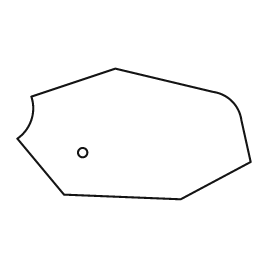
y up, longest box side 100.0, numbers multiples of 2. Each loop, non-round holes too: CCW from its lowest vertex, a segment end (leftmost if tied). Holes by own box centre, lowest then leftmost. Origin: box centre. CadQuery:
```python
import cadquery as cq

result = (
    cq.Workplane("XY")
    .moveTo(20.0, -28.0)
    .lineTo(50.0, -12.0)
    .lineTo(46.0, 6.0)
    .threePointArc((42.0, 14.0), (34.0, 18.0))
    .lineTo(-8.0, 28.0)
    .lineTo(-44.0, 16.0)
    .threePointArc((-44.0, 6.0), (-50.0, -2.0))
    .lineTo(-30.0, -26.0)
    .close()
    .moveTo(-22.0, -8.0)
    .circle(2.0)
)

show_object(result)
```